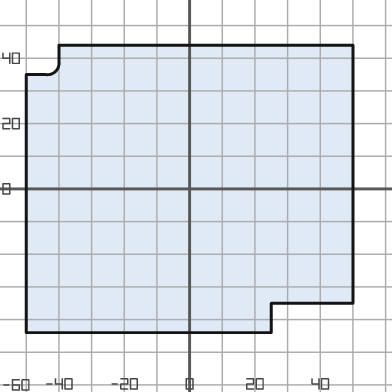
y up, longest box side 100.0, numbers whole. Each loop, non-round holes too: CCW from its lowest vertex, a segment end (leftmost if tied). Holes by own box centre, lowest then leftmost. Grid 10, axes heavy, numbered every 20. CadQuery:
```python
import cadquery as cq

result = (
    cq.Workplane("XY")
    .moveTo(-50.0, -44.0)
    .lineTo(25.0, -44.0)
    .lineTo(25.0, -35.0)
    .lineTo(50.0, -35.0)
    .lineTo(50.0, 44.0)
    .lineTo(-40.0, 44.0)
    .lineTo(-40.0, 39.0)
    .threePointArc((-41.0, 36.0), (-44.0, 35.0))
    .lineTo(-50.0, 35.0)
    .close()
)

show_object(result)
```